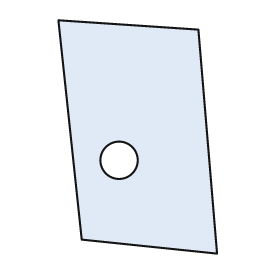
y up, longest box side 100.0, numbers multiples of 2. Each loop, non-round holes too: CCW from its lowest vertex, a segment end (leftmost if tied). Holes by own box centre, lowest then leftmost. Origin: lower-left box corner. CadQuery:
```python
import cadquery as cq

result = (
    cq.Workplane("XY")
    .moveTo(68.0, 0.0)
    .lineTo(60.0, 96.0)
    .lineTo(0.0, 100.0)
    .lineTo(10.0, 6.0)
    .close()
    .moveTo(26.0, 40.0)
    .circle(8.0)
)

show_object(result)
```